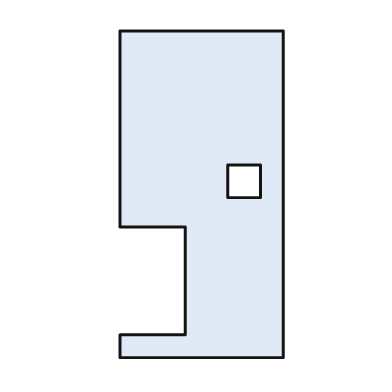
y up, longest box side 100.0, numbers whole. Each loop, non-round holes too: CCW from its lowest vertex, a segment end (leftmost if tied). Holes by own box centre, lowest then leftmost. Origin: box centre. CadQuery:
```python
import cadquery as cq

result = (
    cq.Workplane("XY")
    .moveTo(-25.0, -50.0)
    .lineTo(25.0, -50.0)
    .lineTo(25.0, 50.0)
    .lineTo(-25.0, 50.0)
    .lineTo(-25.0, -10.0)
    .lineTo(-5.0, -10.0)
    .lineTo(-5.0, -43.0)
    .lineTo(-25.0, -43.0)
    .close()
    .moveTo(8.0, -1.0)
    .lineTo(18.0, -1.0)
    .lineTo(18.0, 9.0)
    .lineTo(8.0, 9.0)
    .close()
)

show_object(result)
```